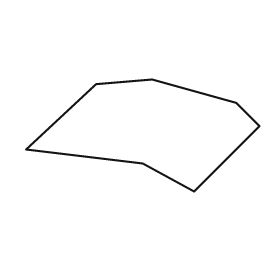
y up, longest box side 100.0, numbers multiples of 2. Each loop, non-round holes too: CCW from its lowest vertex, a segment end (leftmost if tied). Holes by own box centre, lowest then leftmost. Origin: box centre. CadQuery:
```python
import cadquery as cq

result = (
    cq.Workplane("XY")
    .moveTo(22.0, -24.0)
    .lineTo(50.0, 4.0)
    .lineTo(40.0, 14.0)
    .lineTo(4.0, 24.0)
    .lineTo(-20.0, 22.0)
    .lineTo(-50.0, -6.0)
    .lineTo(0.0, -12.0)
    .close()
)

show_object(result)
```